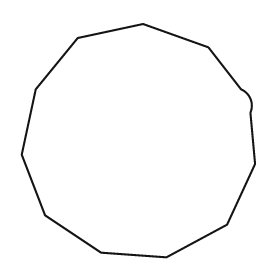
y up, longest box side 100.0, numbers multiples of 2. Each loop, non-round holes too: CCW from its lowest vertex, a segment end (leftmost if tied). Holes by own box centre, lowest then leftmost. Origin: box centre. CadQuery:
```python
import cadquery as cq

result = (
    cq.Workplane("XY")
    .moveTo(12.0, -50.0)
    .lineTo(38.0, -36.0)
    .lineTo(50.0, -10.0)
    .lineTo(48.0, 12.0)
    .threePointArc((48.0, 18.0), (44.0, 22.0))
    .lineTo(30.0, 40.0)
    .lineTo(2.0, 50.0)
    .lineTo(-26.0, 44.0)
    .lineTo(-44.0, 22.0)
    .lineTo(-50.0, -6.0)
    .lineTo(-40.0, -32.0)
    .lineTo(-16.0, -48.0)
    .close()
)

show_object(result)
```